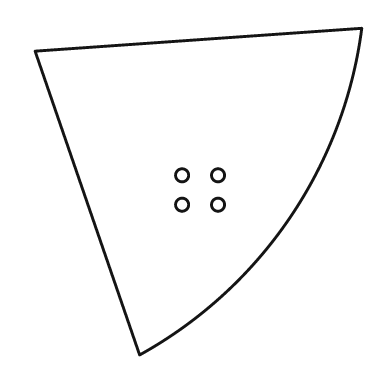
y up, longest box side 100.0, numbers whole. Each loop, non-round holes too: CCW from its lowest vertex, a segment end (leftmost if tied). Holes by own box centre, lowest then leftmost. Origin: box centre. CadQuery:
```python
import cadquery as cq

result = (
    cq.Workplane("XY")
    .moveTo(-18.0, -50.0)
    .threePointArc((28.0, -8.0), (50.0, 50.0))
    .lineTo(-50.0, 43.0)
    .close()
    .moveTo(-5.0, -4.0)
    .circle(2.0)
    .moveTo(6.0, -4.0)
    .circle(2.0)
    .moveTo(-5.0, 5.0)
    .circle(2.0)
    .moveTo(6.0, 5.0)
    .circle(2.0)
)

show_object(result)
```